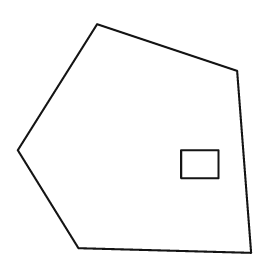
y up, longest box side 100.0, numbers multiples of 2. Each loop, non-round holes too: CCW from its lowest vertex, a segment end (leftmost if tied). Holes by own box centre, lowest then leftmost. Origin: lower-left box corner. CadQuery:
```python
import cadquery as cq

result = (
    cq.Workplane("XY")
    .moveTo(100.0, 0.0)
    .lineTo(94.0, 78.0)
    .lineTo(34.0, 98.0)
    .lineTo(0.0, 44.0)
    .lineTo(26.0, 2.0)
    .close()
    .moveTo(70.0, 32.0)
    .lineTo(86.0, 32.0)
    .lineTo(86.0, 44.0)
    .lineTo(70.0, 44.0)
    .close()
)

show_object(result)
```